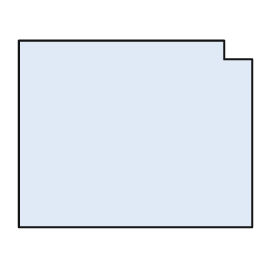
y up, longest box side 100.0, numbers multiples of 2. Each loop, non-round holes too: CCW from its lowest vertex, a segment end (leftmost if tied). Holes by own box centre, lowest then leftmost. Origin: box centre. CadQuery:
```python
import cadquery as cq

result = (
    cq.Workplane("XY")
    .moveTo(-50.0, -40.0)
    .lineTo(50.0, -40.0)
    .lineTo(50.0, 32.0)
    .lineTo(38.0, 32.0)
    .lineTo(38.0, 40.0)
    .lineTo(-50.0, 40.0)
    .close()
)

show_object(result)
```